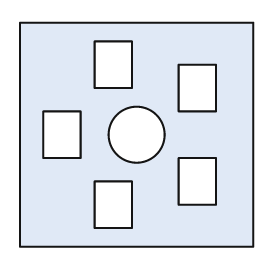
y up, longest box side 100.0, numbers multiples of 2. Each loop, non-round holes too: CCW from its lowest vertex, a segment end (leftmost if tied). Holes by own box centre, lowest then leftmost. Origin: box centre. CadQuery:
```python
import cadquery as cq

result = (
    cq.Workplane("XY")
    .moveTo(-50.0, -48.0)
    .lineTo(50.0, -48.0)
    .lineTo(50.0, 48.0)
    .lineTo(-50.0, 48.0)
    .close()
    .moveTo(-18.0, -40.0)
    .lineTo(-2.0, -40.0)
    .lineTo(-2.0, -20.0)
    .lineTo(-18.0, -20.0)
    .close()
    .moveTo(18.0, -30.0)
    .lineTo(34.0, -30.0)
    .lineTo(34.0, -10.0)
    .lineTo(18.0, -10.0)
    .close()
    .moveTo(-40.0, -10.0)
    .lineTo(-24.0, -10.0)
    .lineTo(-24.0, 10.0)
    .lineTo(-40.0, 10.0)
    .close()
    .moveTo(0.0, 0.0)
    .circle(12.0)
    .moveTo(18.0, 10.0)
    .lineTo(34.0, 10.0)
    .lineTo(34.0, 30.0)
    .lineTo(18.0, 30.0)
    .close()
    .moveTo(-18.0, 20.0)
    .lineTo(-2.0, 20.0)
    .lineTo(-2.0, 40.0)
    .lineTo(-18.0, 40.0)
    .close()
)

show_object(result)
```